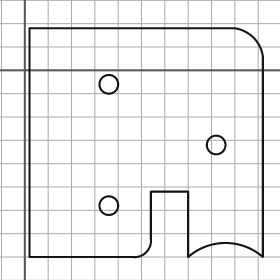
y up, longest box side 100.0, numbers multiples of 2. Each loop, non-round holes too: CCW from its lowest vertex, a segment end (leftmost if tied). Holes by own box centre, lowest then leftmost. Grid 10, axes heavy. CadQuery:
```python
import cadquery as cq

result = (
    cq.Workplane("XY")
    .moveTo(2.0, -80.0)
    .lineTo(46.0, -80.0)
    .threePointArc((52.0, -78.0), (54.0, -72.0))
    .lineTo(54.0, -52.0)
    .lineTo(70.0, -52.0)
    .lineTo(70.0, -80.0)
    .threePointArc((86.0, -74.0), (102.0, -80.0))
    .lineTo(102.0, 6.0)
    .threePointArc((98.0, 14.0), (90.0, 18.0))
    .lineTo(2.0, 18.0)
    .close()
    .moveTo(36.0, -58.0)
    .circle(4.0)
    .moveTo(82.0, -32.0)
    .circle(4.0)
    .moveTo(36.0, -6.0)
    .circle(4.0)
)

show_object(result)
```